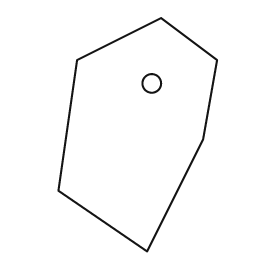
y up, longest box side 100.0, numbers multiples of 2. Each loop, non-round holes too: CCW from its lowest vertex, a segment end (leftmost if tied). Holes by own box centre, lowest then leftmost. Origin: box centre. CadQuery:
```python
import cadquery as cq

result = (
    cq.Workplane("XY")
    .moveTo(4.0, -50.0)
    .lineTo(28.0, -2.0)
    .lineTo(34.0, 32.0)
    .lineTo(10.0, 50.0)
    .lineTo(-26.0, 32.0)
    .lineTo(-34.0, -24.0)
    .close()
    .moveTo(6.0, 22.0)
    .circle(4.0)
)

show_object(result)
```